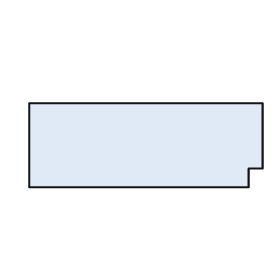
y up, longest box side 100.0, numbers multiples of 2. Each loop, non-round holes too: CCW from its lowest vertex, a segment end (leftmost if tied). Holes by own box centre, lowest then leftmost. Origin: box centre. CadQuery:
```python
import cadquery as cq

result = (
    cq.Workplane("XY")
    .moveTo(-50.0, -18.0)
    .lineTo(44.0, -18.0)
    .lineTo(44.0, -10.0)
    .lineTo(50.0, -10.0)
    .lineTo(50.0, 18.0)
    .lineTo(-50.0, 18.0)
    .close()
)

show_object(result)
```